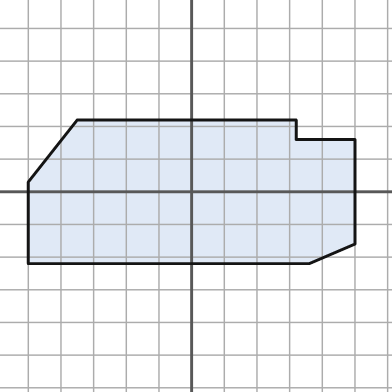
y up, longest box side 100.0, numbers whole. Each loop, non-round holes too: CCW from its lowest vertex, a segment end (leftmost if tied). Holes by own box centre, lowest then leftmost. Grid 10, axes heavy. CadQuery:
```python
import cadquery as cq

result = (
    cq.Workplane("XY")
    .moveTo(-50.0, -22.0)
    .lineTo(36.0, -22.0)
    .lineTo(50.0, -16.0)
    .lineTo(50.0, 16.0)
    .lineTo(32.0, 16.0)
    .lineTo(32.0, 22.0)
    .lineTo(-35.0, 22.0)
    .lineTo(-50.0, 3.0)
    .close()
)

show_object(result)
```